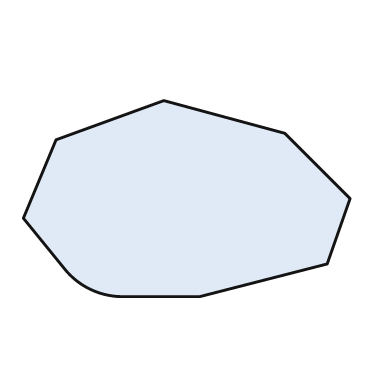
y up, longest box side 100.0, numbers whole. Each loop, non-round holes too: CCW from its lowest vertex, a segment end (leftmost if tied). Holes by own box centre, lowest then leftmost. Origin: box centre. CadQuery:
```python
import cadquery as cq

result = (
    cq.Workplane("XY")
    .moveTo(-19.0, -30.0)
    .lineTo(4.0, -30.0)
    .lineTo(43.0, -20.0)
    .lineTo(50.0, 0.0)
    .lineTo(30.0, 20.0)
    .lineTo(-7.0, 30.0)
    .lineTo(-40.0, 18.0)
    .lineTo(-50.0, -6.0)
    .lineTo(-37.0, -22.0)
    .threePointArc((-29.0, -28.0), (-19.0, -30.0))
    .close()
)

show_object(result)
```